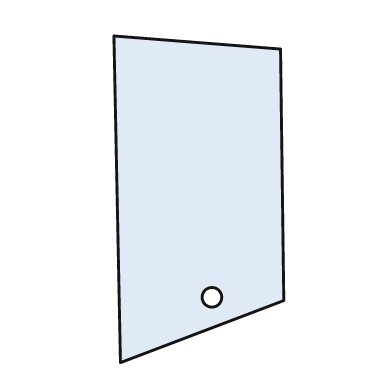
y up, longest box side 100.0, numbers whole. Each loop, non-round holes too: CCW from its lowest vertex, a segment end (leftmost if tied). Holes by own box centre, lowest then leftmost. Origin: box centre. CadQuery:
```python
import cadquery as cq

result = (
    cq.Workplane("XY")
    .moveTo(-24.0, -50.0)
    .lineTo(26.0, -31.0)
    .lineTo(25.0, 46.0)
    .lineTo(-26.0, 50.0)
    .close()
    .moveTo(4.0, -30.0)
    .circle(3.0)
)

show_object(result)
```